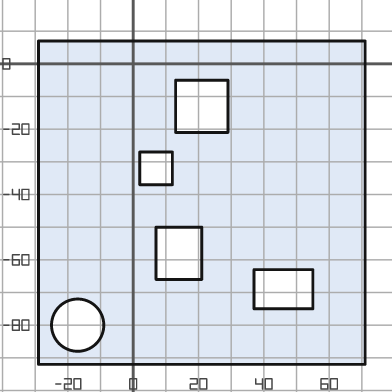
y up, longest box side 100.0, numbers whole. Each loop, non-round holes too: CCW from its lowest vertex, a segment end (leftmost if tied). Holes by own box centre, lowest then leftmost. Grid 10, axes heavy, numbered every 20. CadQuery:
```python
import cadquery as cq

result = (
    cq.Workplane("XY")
    .moveTo(-29.0, -92.0)
    .lineTo(71.0, -92.0)
    .lineTo(71.0, 7.0)
    .lineTo(-29.0, 7.0)
    .close()
    .moveTo(-17.0, -80.0)
    .circle(8.0)
    .moveTo(37.0, -75.0)
    .lineTo(55.0, -75.0)
    .lineTo(55.0, -63.0)
    .lineTo(37.0, -63.0)
    .close()
    .moveTo(7.0, -66.0)
    .lineTo(21.0, -66.0)
    .lineTo(21.0, -50.0)
    .lineTo(7.0, -50.0)
    .close()
    .moveTo(2.0, -37.0)
    .lineTo(12.0, -37.0)
    .lineTo(12.0, -27.0)
    .lineTo(2.0, -27.0)
    .close()
    .moveTo(13.0, -21.0)
    .lineTo(29.0, -21.0)
    .lineTo(29.0, -5.0)
    .lineTo(13.0, -5.0)
    .close()
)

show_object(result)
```